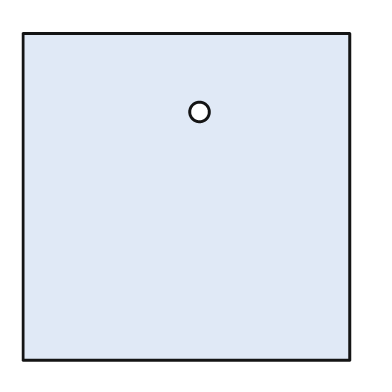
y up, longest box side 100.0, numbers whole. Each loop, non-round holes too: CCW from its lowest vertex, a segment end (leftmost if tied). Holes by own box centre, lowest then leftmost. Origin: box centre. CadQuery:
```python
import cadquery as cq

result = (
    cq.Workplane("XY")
    .moveTo(-50.0, -50.0)
    .lineTo(50.0, -50.0)
    .lineTo(50.0, 50.0)
    .lineTo(-50.0, 50.0)
    .close()
    .moveTo(4.0, 26.0)
    .circle(3.0)
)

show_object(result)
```